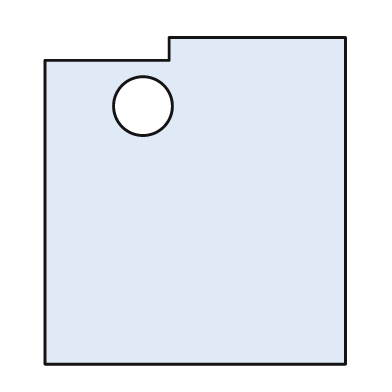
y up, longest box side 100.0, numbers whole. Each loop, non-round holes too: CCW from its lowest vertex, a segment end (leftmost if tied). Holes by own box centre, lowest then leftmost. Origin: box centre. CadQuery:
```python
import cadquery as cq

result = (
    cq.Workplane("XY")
    .moveTo(-46.0, -50.0)
    .lineTo(46.0, -50.0)
    .lineTo(46.0, 50.0)
    .lineTo(-8.0, 50.0)
    .lineTo(-8.0, 43.0)
    .lineTo(-46.0, 43.0)
    .close()
    .moveTo(-16.0, 29.0)
    .circle(9.0)
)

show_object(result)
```